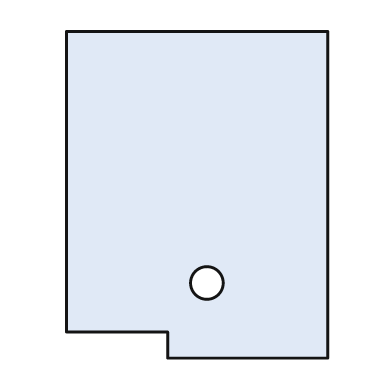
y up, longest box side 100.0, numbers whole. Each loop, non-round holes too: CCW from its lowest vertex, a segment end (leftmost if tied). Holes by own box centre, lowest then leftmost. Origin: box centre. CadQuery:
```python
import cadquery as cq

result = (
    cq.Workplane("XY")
    .moveTo(-9.0, -50.0)
    .lineTo(40.0, -50.0)
    .lineTo(40.0, 50.0)
    .lineTo(-40.0, 50.0)
    .lineTo(-40.0, -42.0)
    .lineTo(-9.0, -42.0)
    .close()
    .moveTo(3.0, -27.0)
    .circle(5.0)
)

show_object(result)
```